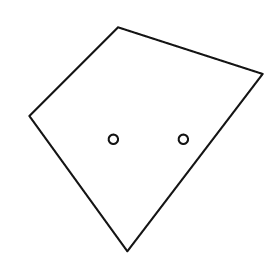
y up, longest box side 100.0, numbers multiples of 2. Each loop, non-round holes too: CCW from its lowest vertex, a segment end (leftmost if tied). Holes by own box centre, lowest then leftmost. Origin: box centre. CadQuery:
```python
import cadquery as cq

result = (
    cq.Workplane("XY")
    .moveTo(-8.0, -48.0)
    .lineTo(50.0, 28.0)
    .lineTo(-12.0, 48.0)
    .lineTo(-50.0, 10.0)
    .close()
    .moveTo(-14.0, 0.0)
    .circle(2.0)
    .moveTo(16.0, 0.0)
    .circle(2.0)
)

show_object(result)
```